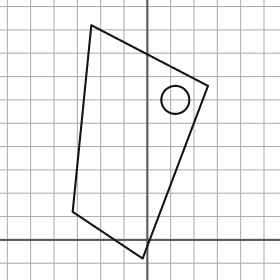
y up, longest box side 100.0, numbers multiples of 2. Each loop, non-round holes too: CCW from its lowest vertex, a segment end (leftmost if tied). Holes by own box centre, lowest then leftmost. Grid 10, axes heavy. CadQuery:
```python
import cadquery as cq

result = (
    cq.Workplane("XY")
    .moveTo(-2.0, -8.0)
    .lineTo(26.0, 66.0)
    .lineTo(-24.0, 92.0)
    .lineTo(-32.0, 12.0)
    .close()
    .moveTo(12.0, 60.0)
    .circle(6.0)
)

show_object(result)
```